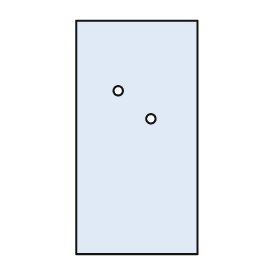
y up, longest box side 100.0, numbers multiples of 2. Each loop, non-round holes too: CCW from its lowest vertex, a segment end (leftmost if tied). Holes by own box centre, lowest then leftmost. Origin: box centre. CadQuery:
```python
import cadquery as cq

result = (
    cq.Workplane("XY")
    .moveTo(-26.0, -50.0)
    .lineTo(26.0, -50.0)
    .lineTo(26.0, 50.0)
    .lineTo(-26.0, 50.0)
    .close()
    .moveTo(6.0, 8.0)
    .circle(2.0)
    .moveTo(-8.0, 20.0)
    .circle(2.0)
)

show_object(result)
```